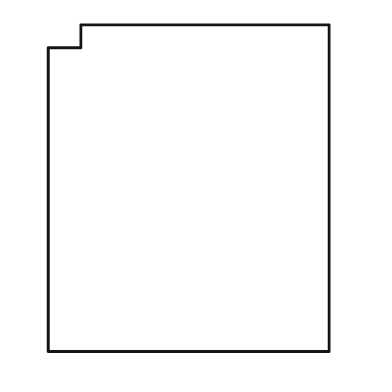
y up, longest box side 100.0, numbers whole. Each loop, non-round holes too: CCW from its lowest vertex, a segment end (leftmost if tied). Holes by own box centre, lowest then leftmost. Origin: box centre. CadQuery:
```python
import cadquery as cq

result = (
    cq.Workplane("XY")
    .moveTo(-43.0, -50.0)
    .lineTo(43.0, -50.0)
    .lineTo(43.0, 50.0)
    .lineTo(-33.0, 50.0)
    .lineTo(-33.0, 43.0)
    .lineTo(-43.0, 43.0)
    .close()
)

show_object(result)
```